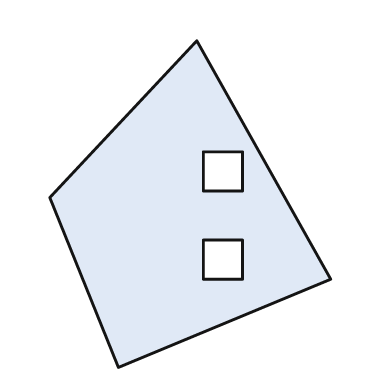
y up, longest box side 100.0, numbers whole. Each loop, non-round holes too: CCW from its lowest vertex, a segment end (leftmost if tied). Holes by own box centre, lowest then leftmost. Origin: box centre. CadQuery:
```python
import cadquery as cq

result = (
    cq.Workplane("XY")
    .moveTo(-22.0, -50.0)
    .lineTo(43.0, -23.0)
    .lineTo(2.0, 50.0)
    .lineTo(-43.0, 2.0)
    .close()
    .moveTo(4.0, -23.0)
    .lineTo(16.0, -23.0)
    .lineTo(16.0, -11.0)
    .lineTo(4.0, -11.0)
    .close()
    .moveTo(4.0, 4.0)
    .lineTo(16.0, 4.0)
    .lineTo(16.0, 16.0)
    .lineTo(4.0, 16.0)
    .close()
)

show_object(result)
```